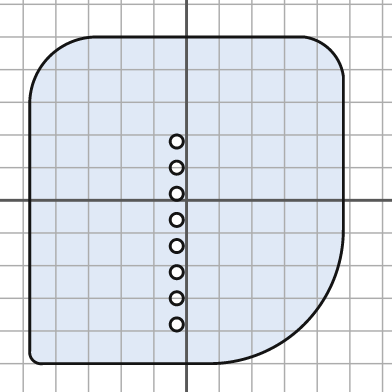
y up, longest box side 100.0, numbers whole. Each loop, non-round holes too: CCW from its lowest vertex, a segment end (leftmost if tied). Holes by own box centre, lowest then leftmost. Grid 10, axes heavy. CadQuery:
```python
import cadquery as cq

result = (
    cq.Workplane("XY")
    .moveTo(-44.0, -50.0)
    .lineTo(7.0, -50.0)
    .threePointArc((36.0, -38.0), (48.0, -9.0))
    .lineTo(48.0, 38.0)
    .threePointArc((44.0, 46.0), (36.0, 50.0))
    .lineTo(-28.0, 50.0)
    .threePointArc((-42.0, 44.0), (-48.0, 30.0))
    .lineTo(-48.0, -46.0)
    .threePointArc((-47.0, -49.0), (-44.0, -50.0))
    .close()
    .moveTo(-3.0, -38.0)
    .circle(2.0)
    .moveTo(-3.0, -30.0)
    .circle(2.0)
    .moveTo(-3.0, -22.0)
    .circle(2.0)
    .moveTo(-3.0, -14.0)
    .circle(2.0)
    .moveTo(-3.0, -6.0)
    .circle(2.0)
    .moveTo(-3.0, 2.0)
    .circle(2.0)
    .moveTo(-3.0, 10.0)
    .circle(2.0)
    .moveTo(-3.0, 18.0)
    .circle(2.0)
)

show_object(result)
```